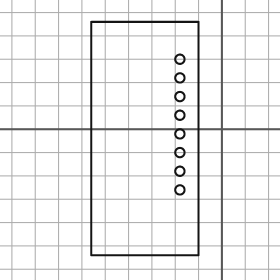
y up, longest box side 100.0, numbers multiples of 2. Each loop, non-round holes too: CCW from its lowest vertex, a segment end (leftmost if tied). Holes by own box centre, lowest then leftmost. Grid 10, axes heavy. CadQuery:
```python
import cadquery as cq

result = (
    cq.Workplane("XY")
    .moveTo(-56.0, -54.0)
    .lineTo(-10.0, -54.0)
    .lineTo(-10.0, 46.0)
    .lineTo(-56.0, 46.0)
    .close()
    .moveTo(-18.0, -26.0)
    .circle(2.0)
    .moveTo(-18.0, -18.0)
    .circle(2.0)
    .moveTo(-18.0, -10.0)
    .circle(2.0)
    .moveTo(-18.0, -2.0)
    .circle(2.0)
    .moveTo(-18.0, 6.0)
    .circle(2.0)
    .moveTo(-18.0, 14.0)
    .circle(2.0)
    .moveTo(-18.0, 22.0)
    .circle(2.0)
    .moveTo(-18.0, 30.0)
    .circle(2.0)
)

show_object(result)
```